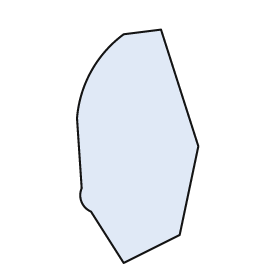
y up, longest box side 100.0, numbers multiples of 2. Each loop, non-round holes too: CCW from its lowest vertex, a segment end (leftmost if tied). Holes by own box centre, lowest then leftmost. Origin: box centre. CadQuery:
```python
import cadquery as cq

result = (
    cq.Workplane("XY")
    .moveTo(-6.0, -50.0)
    .lineTo(18.0, -38.0)
    .lineTo(26.0, 0.0)
    .lineTo(10.0, 50.0)
    .lineTo(-6.0, 48.0)
    .threePointArc((-20.0, 32.0), (-26.0, 12.0))
    .lineTo(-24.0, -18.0)
    .threePointArc((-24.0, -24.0), (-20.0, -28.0))
    .close()
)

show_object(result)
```